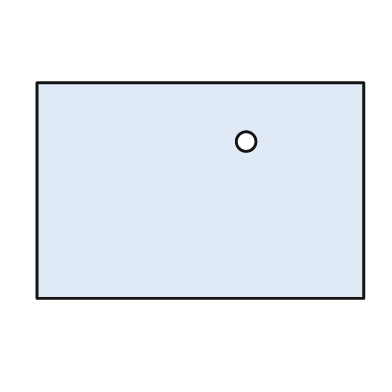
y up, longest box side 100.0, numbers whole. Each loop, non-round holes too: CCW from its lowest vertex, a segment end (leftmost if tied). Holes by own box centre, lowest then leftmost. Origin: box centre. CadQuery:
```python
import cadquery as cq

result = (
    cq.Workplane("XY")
    .moveTo(-50.0, -33.0)
    .lineTo(50.0, -33.0)
    .lineTo(50.0, 33.0)
    .lineTo(-50.0, 33.0)
    .close()
    .moveTo(14.0, 15.0)
    .circle(3.0)
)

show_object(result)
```